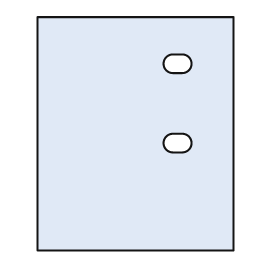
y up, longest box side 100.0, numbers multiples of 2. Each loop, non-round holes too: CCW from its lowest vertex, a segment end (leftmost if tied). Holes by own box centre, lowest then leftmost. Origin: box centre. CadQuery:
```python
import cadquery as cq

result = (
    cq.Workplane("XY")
    .moveTo(-42.0, -50.0)
    .lineTo(42.0, -50.0)
    .lineTo(42.0, 50.0)
    .lineTo(-42.0, 50.0)
    .close()
    .moveTo(16.0, -8.0)
    .lineTo(20.0, -8.0)
    .threePointArc((24.0, -4.0), (20.0, 0.0))
    .lineTo(16.0, 0.0)
    .threePointArc((12.0, -4.0), (16.0, -8.0))
    .close()
    .moveTo(16.0, 26.0)
    .lineTo(20.0, 26.0)
    .threePointArc((24.0, 30.0), (20.0, 34.0))
    .lineTo(16.0, 34.0)
    .threePointArc((12.0, 30.0), (16.0, 26.0))
    .close()
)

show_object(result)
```